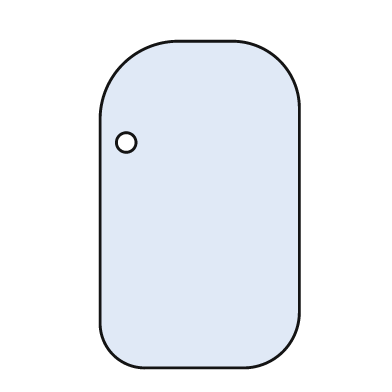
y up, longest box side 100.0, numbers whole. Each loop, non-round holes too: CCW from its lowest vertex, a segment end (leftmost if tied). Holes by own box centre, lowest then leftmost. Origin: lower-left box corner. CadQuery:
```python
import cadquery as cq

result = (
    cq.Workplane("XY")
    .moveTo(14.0, 0.0)
    .lineTo(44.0, 0.0)
    .threePointArc((56.0, 5.0), (61.0, 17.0))
    .lineTo(61.0, 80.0)
    .threePointArc((55.0, 94.0), (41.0, 100.0))
    .lineTo(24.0, 100.0)
    .threePointArc((7.0, 93.0), (0.0, 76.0))
    .lineTo(0.0, 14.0)
    .threePointArc((4.0, 4.0), (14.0, 0.0))
    .close()
    .moveTo(8.0, 69.0)
    .circle(3.0)
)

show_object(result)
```